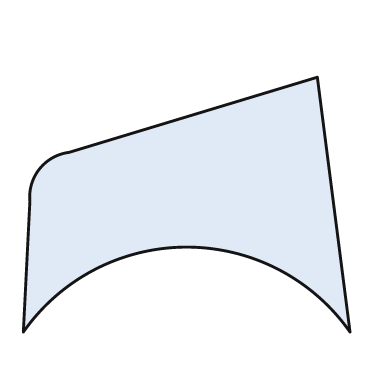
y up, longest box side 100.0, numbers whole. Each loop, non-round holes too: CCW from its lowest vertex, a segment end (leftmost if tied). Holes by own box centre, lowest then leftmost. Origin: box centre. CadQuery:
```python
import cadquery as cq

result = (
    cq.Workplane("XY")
    .moveTo(-50.0, -39.0)
    .threePointArc((0.0, -13.0), (50.0, -39.0))
    .lineTo(40.0, 39.0)
    .lineTo(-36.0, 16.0)
    .threePointArc((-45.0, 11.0), (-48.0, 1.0))
    .close()
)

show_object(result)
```